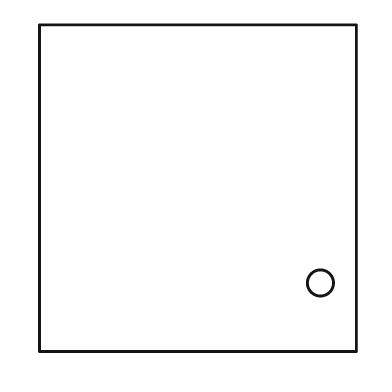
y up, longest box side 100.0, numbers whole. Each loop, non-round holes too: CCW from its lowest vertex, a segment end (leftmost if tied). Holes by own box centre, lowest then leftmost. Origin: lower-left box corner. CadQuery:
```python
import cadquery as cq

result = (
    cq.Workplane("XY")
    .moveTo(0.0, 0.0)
    .lineTo(97.0, 0.0)
    .lineTo(97.0, 100.0)
    .lineTo(0.0, 100.0)
    .close()
    .moveTo(86.0, 21.0)
    .circle(4.0)
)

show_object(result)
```